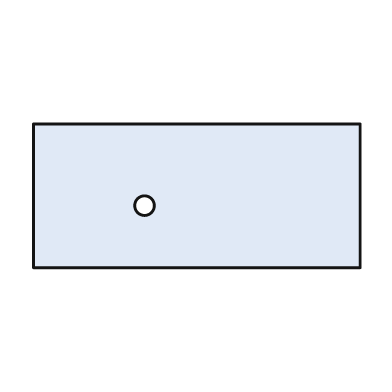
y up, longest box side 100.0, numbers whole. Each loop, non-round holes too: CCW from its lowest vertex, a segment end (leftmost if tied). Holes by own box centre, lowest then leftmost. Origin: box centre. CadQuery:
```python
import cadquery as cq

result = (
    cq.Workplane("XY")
    .moveTo(-50.0, -22.0)
    .lineTo(50.0, -22.0)
    .lineTo(50.0, 22.0)
    .lineTo(-50.0, 22.0)
    .close()
    .moveTo(-16.0, -3.0)
    .circle(3.0)
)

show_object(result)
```